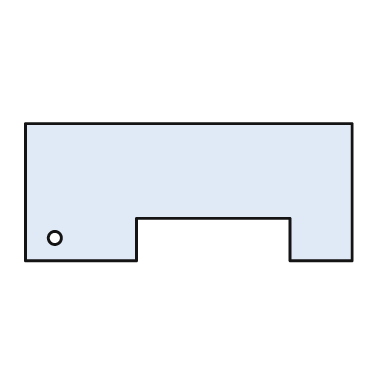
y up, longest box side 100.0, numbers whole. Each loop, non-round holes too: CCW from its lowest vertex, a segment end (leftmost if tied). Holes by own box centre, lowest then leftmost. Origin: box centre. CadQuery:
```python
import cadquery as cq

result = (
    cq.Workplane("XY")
    .moveTo(-50.0, -21.0)
    .lineTo(-16.0, -21.0)
    .lineTo(-16.0, -8.0)
    .lineTo(31.0, -8.0)
    .lineTo(31.0, -21.0)
    .lineTo(50.0, -21.0)
    .lineTo(50.0, 21.0)
    .lineTo(-50.0, 21.0)
    .close()
    .moveTo(-41.0, -14.0)
    .circle(2.0)
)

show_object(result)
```